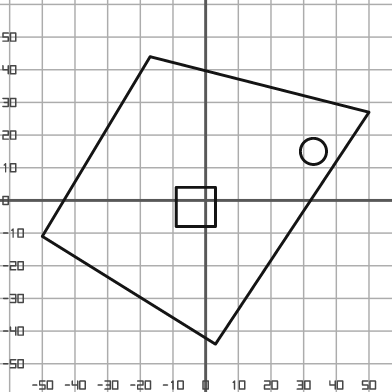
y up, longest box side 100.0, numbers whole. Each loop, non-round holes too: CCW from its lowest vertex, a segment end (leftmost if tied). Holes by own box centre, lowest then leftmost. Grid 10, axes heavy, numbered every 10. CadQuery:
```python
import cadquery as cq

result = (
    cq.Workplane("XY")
    .moveTo(3.0, -44.0)
    .lineTo(50.0, 27.0)
    .lineTo(-17.0, 44.0)
    .lineTo(-50.0, -11.0)
    .close()
    .moveTo(-9.0, -8.0)
    .lineTo(3.0, -8.0)
    .lineTo(3.0, 4.0)
    .lineTo(-9.0, 4.0)
    .close()
    .moveTo(33.0, 15.0)
    .circle(4.0)
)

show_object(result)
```